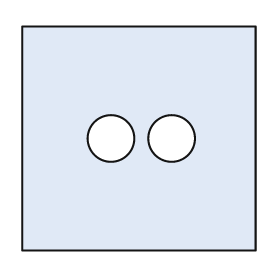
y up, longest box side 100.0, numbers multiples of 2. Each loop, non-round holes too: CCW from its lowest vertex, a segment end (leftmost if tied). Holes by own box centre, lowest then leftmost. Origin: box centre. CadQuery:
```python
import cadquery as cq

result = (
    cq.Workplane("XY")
    .moveTo(-50.0, -48.0)
    .lineTo(50.0, -48.0)
    .lineTo(50.0, 48.0)
    .lineTo(-50.0, 48.0)
    .close()
    .moveTo(-12.0, 0.0)
    .circle(10.0)
    .moveTo(14.0, 0.0)
    .circle(10.0)
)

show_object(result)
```